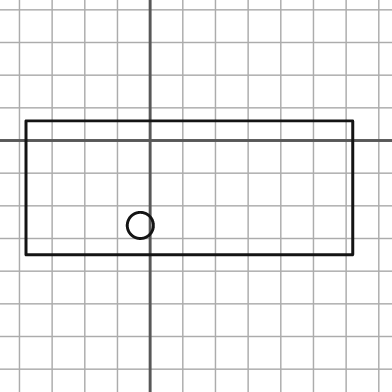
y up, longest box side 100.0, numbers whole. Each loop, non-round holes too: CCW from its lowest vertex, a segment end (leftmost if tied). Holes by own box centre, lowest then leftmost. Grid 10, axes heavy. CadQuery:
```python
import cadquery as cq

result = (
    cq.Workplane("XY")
    .moveTo(-38.0, -35.0)
    .lineTo(62.0, -35.0)
    .lineTo(62.0, 6.0)
    .lineTo(-38.0, 6.0)
    .close()
    .moveTo(-3.0, -26.0)
    .circle(4.0)
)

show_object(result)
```